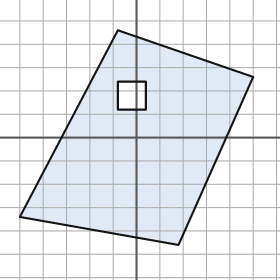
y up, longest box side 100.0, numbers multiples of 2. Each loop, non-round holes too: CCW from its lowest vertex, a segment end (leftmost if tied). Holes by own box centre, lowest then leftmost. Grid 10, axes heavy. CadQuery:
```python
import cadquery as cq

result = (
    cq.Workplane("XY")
    .moveTo(18.0, -46.0)
    .lineTo(50.0, 26.0)
    .lineTo(-8.0, 46.0)
    .lineTo(-50.0, -34.0)
    .close()
    .moveTo(-8.0, 12.0)
    .lineTo(4.0, 12.0)
    .lineTo(4.0, 24.0)
    .lineTo(-8.0, 24.0)
    .close()
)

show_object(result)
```